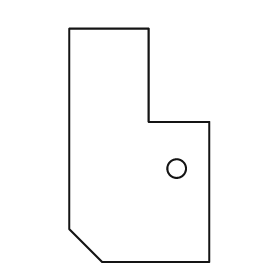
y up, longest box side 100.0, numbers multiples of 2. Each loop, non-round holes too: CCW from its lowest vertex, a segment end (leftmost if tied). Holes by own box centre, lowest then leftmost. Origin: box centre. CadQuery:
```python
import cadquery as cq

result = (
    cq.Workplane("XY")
    .moveTo(-16.0, -50.0)
    .lineTo(30.0, -50.0)
    .lineTo(30.0, 10.0)
    .lineTo(4.0, 10.0)
    .lineTo(4.0, 50.0)
    .lineTo(-30.0, 50.0)
    .lineTo(-30.0, -36.0)
    .close()
    .moveTo(16.0, -10.0)
    .circle(4.0)
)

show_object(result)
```